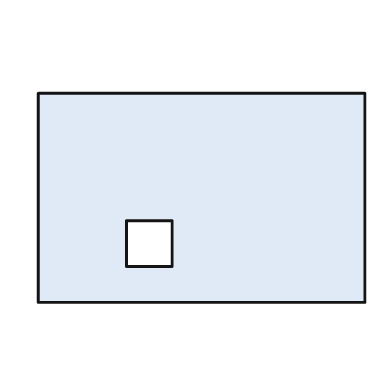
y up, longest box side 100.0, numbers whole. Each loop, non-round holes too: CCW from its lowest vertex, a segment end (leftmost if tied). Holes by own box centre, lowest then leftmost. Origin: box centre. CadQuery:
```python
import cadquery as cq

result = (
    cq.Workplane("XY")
    .moveTo(-50.0, -32.0)
    .lineTo(50.0, -32.0)
    .lineTo(50.0, 32.0)
    .lineTo(-50.0, 32.0)
    .close()
    .moveTo(-23.0, -21.0)
    .lineTo(-9.0, -21.0)
    .lineTo(-9.0, -7.0)
    .lineTo(-23.0, -7.0)
    .close()
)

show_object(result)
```